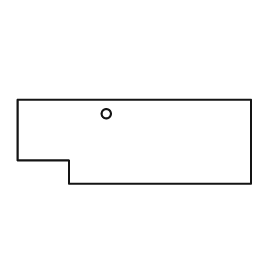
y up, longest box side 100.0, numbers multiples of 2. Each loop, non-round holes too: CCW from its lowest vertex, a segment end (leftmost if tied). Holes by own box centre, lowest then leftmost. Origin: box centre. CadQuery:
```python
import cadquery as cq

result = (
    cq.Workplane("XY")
    .moveTo(-28.0, -18.0)
    .lineTo(50.0, -18.0)
    .lineTo(50.0, 18.0)
    .lineTo(-50.0, 18.0)
    .lineTo(-50.0, -8.0)
    .lineTo(-28.0, -8.0)
    .close()
    .moveTo(-12.0, 12.0)
    .circle(2.0)
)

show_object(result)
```